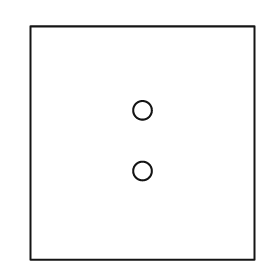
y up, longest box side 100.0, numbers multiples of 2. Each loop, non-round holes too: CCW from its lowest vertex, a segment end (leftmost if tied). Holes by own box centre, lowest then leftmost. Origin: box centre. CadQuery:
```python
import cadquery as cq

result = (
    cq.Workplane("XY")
    .moveTo(-48.0, -50.0)
    .lineTo(48.0, -50.0)
    .lineTo(48.0, 50.0)
    .lineTo(-48.0, 50.0)
    .close()
    .moveTo(0.0, -12.0)
    .circle(4.0)
    .moveTo(0.0, 14.0)
    .circle(4.0)
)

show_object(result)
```